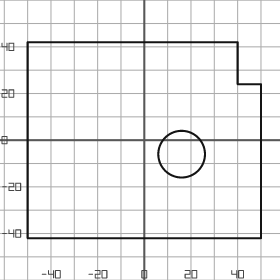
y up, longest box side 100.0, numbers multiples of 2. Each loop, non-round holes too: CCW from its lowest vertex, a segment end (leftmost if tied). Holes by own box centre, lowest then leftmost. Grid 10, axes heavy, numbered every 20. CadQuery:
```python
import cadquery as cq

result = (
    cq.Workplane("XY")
    .moveTo(-50.0, -42.0)
    .lineTo(50.0, -42.0)
    .lineTo(50.0, 24.0)
    .lineTo(40.0, 24.0)
    .lineTo(40.0, 42.0)
    .lineTo(-50.0, 42.0)
    .close()
    .moveTo(16.0, -6.0)
    .circle(10.0)
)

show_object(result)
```